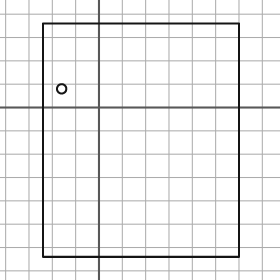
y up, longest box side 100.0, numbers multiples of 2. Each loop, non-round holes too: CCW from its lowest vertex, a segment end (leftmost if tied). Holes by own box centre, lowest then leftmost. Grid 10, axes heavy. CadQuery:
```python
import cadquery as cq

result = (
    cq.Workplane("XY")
    .moveTo(-24.0, -64.0)
    .lineTo(60.0, -64.0)
    .lineTo(60.0, 36.0)
    .lineTo(-24.0, 36.0)
    .close()
    .moveTo(-16.0, 8.0)
    .circle(2.0)
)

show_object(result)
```